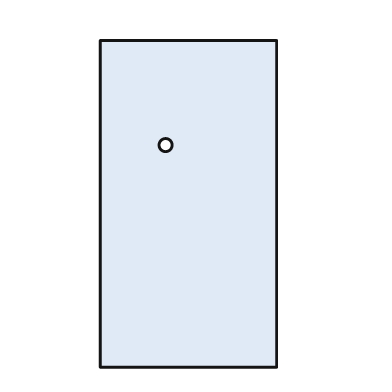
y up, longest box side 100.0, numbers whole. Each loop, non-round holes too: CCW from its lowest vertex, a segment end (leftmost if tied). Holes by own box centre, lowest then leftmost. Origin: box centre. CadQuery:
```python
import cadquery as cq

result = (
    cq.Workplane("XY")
    .moveTo(-27.0, -50.0)
    .lineTo(27.0, -50.0)
    .lineTo(27.0, 50.0)
    .lineTo(-27.0, 50.0)
    .close()
    .moveTo(-7.0, 18.0)
    .circle(2.0)
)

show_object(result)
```